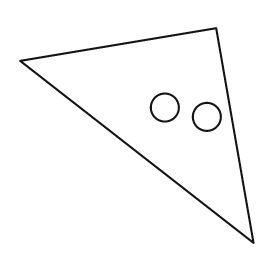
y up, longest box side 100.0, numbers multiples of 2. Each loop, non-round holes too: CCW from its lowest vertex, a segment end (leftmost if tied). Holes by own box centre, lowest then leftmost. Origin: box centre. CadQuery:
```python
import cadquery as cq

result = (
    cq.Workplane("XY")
    .moveTo(50.0, -46.0)
    .lineTo(34.0, 46.0)
    .lineTo(-50.0, 32.0)
    .close()
    .moveTo(30.0, 8.0)
    .circle(6.0)
    .moveTo(12.0, 12.0)
    .circle(6.0)
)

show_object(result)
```